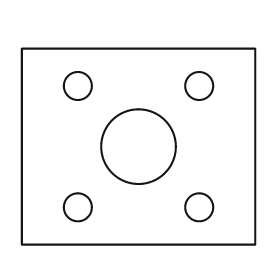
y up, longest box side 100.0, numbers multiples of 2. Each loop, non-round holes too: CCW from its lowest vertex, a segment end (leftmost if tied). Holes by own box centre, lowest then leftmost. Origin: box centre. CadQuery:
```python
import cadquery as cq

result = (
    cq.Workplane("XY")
    .moveTo(-50.0, -42.0)
    .lineTo(50.0, -42.0)
    .lineTo(50.0, 42.0)
    .lineTo(-50.0, 42.0)
    .close()
    .moveTo(-26.0, -26.0)
    .circle(6.0)
    .moveTo(26.0, -26.0)
    .circle(6.0)
    .moveTo(0.0, 0.0)
    .circle(16.0)
    .moveTo(-26.0, 26.0)
    .circle(6.0)
    .moveTo(26.0, 26.0)
    .circle(6.0)
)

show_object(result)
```